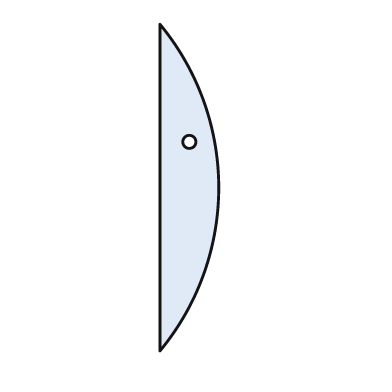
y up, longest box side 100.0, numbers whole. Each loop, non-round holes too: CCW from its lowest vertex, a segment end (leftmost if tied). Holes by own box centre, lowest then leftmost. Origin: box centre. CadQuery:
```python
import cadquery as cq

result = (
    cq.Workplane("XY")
    .moveTo(-9.0, -50.0)
    .threePointArc((9.0, 0.0), (-9.0, 50.0))
    .close()
    .moveTo(0.0, 14.0)
    .circle(2.0)
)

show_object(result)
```